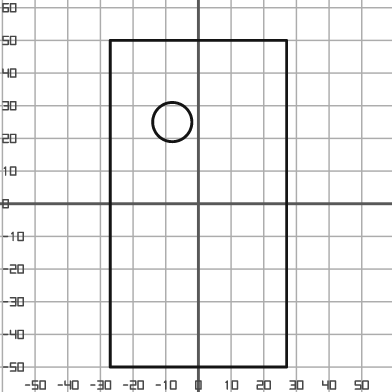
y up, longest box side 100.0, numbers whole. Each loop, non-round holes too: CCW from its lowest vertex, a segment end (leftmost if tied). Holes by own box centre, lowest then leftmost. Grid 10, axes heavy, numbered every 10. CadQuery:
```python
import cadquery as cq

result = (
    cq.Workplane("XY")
    .moveTo(-27.0, -50.0)
    .lineTo(27.0, -50.0)
    .lineTo(27.0, 50.0)
    .lineTo(-27.0, 50.0)
    .close()
    .moveTo(-8.0, 25.0)
    .circle(6.0)
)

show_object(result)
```